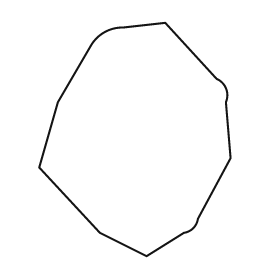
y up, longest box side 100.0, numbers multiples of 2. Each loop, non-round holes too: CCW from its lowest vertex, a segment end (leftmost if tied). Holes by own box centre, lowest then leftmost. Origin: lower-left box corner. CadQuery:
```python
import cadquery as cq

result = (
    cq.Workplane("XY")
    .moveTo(46.0, 0.0)
    .lineTo(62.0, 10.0)
    .threePointArc((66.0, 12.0), (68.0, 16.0))
    .lineTo(82.0, 42.0)
    .lineTo(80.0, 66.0)
    .threePointArc((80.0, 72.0), (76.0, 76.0))
    .lineTo(54.0, 100.0)
    .lineTo(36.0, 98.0)
    .threePointArc((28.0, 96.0), (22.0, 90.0))
    .lineTo(8.0, 66.0)
    .lineTo(0.0, 38.0)
    .lineTo(26.0, 10.0)
    .close()
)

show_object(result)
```